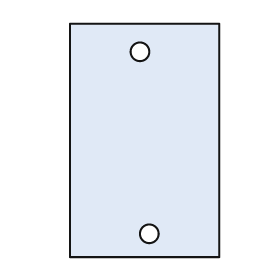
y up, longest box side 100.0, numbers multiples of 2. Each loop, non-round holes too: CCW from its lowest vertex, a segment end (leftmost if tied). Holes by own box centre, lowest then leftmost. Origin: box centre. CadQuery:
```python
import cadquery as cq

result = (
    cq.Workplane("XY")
    .moveTo(-32.0, -50.0)
    .lineTo(32.0, -50.0)
    .lineTo(32.0, 50.0)
    .lineTo(-32.0, 50.0)
    .close()
    .moveTo(2.0, -40.0)
    .circle(4.0)
    .moveTo(-2.0, 38.0)
    .circle(4.0)
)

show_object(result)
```